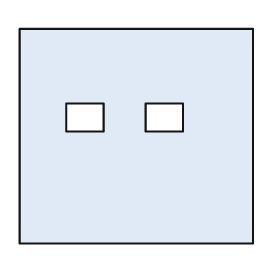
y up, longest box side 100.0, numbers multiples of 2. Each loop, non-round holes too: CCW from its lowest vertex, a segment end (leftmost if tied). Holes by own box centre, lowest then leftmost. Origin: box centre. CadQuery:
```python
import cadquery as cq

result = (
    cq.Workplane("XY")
    .moveTo(-50.0, -46.0)
    .lineTo(50.0, -46.0)
    .lineTo(50.0, 46.0)
    .lineTo(-50.0, 46.0)
    .close()
    .moveTo(-30.0, 2.0)
    .lineTo(-14.0, 2.0)
    .lineTo(-14.0, 14.0)
    .lineTo(-30.0, 14.0)
    .close()
    .moveTo(4.0, 2.0)
    .lineTo(20.0, 2.0)
    .lineTo(20.0, 14.0)
    .lineTo(4.0, 14.0)
    .close()
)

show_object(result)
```